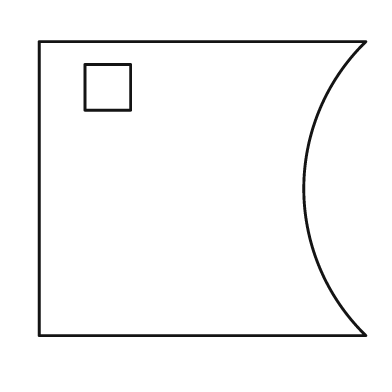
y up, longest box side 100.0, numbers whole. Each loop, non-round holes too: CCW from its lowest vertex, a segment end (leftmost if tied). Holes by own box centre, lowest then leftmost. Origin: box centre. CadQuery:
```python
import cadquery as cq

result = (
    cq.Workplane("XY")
    .moveTo(-50.0, -45.0)
    .lineTo(50.0, -45.0)
    .threePointArc((31.0, 0.0), (50.0, 45.0))
    .lineTo(-50.0, 45.0)
    .close()
    .moveTo(-36.0, 24.0)
    .lineTo(-22.0, 24.0)
    .lineTo(-22.0, 38.0)
    .lineTo(-36.0, 38.0)
    .close()
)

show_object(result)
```